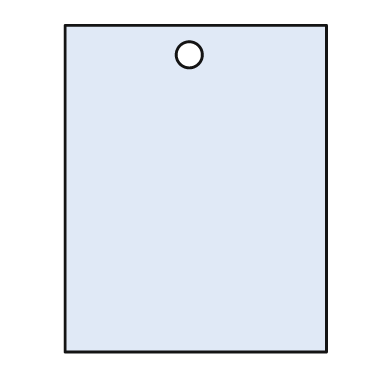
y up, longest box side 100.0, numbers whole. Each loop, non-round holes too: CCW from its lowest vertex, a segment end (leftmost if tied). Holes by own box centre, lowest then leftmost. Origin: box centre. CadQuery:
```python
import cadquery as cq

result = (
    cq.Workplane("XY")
    .moveTo(-40.0, -50.0)
    .lineTo(40.0, -50.0)
    .lineTo(40.0, 50.0)
    .lineTo(-40.0, 50.0)
    .close()
    .moveTo(-2.0, 41.0)
    .circle(4.0)
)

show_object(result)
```